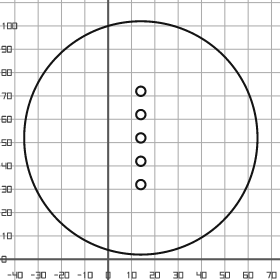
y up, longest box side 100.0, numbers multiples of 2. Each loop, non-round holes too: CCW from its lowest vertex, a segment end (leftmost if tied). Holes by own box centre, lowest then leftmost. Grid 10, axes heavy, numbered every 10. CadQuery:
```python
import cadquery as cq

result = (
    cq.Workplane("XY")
    .moveTo(14.0, 52.0)
    .circle(50.0)
    .moveTo(14.0, 32.0)
    .circle(2.0)
    .moveTo(14.0, 42.0)
    .circle(2.0)
    .moveTo(14.0, 52.0)
    .circle(2.0)
    .moveTo(14.0, 62.0)
    .circle(2.0)
    .moveTo(14.0, 72.0)
    .circle(2.0)
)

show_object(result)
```